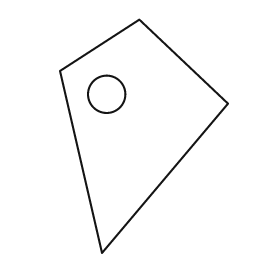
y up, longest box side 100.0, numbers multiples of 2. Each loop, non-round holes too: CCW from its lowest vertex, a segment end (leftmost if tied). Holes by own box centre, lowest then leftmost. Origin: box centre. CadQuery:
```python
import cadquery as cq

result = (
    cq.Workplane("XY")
    .moveTo(-18.0, -50.0)
    .lineTo(36.0, 14.0)
    .lineTo(-2.0, 50.0)
    .lineTo(-36.0, 28.0)
    .close()
    .moveTo(-16.0, 18.0)
    .circle(8.0)
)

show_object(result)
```